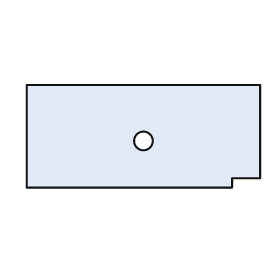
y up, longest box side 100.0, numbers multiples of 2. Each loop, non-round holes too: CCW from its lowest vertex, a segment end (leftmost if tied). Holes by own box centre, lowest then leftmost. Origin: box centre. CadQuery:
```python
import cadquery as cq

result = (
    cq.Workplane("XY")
    .moveTo(-50.0, -22.0)
    .lineTo(38.0, -22.0)
    .lineTo(38.0, -18.0)
    .lineTo(50.0, -18.0)
    .lineTo(50.0, 22.0)
    .lineTo(-50.0, 22.0)
    .close()
    .moveTo(0.0, -2.0)
    .circle(4.0)
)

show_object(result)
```